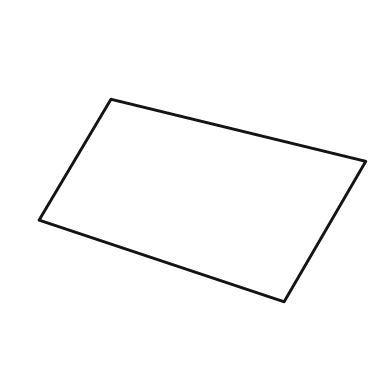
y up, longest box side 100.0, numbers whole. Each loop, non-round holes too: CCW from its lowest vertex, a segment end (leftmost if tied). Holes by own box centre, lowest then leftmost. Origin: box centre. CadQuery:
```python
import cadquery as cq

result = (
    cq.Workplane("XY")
    .moveTo(25.0, -31.0)
    .lineTo(50.0, 12.0)
    .lineTo(-28.0, 31.0)
    .lineTo(-50.0, -6.0)
    .close()
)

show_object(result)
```